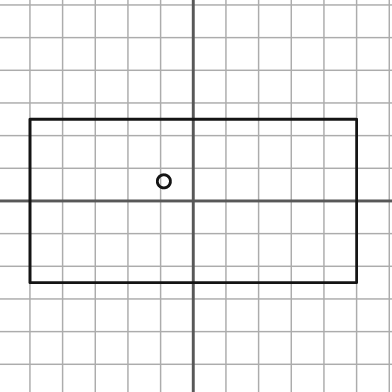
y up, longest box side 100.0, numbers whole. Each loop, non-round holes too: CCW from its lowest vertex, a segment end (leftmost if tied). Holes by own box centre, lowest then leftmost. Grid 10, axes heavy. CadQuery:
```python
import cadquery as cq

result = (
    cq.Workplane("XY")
    .moveTo(-50.0, -25.0)
    .lineTo(50.0, -25.0)
    .lineTo(50.0, 25.0)
    .lineTo(-50.0, 25.0)
    .close()
    .moveTo(-9.0, 6.0)
    .circle(2.0)
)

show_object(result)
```